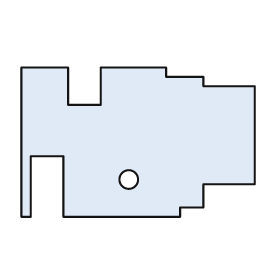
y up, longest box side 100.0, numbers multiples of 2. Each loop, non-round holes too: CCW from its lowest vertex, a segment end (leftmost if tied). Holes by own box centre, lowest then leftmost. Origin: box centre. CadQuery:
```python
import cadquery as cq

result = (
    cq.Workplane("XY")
    .moveTo(-50.0, -32.0)
    .lineTo(-46.0, -32.0)
    .lineTo(-46.0, -6.0)
    .lineTo(-32.0, -6.0)
    .lineTo(-32.0, -32.0)
    .lineTo(18.0, -32.0)
    .lineTo(18.0, -28.0)
    .lineTo(28.0, -28.0)
    .lineTo(28.0, -18.0)
    .lineTo(50.0, -18.0)
    .lineTo(50.0, 24.0)
    .lineTo(28.0, 24.0)
    .lineTo(28.0, 28.0)
    .lineTo(12.0, 28.0)
    .lineTo(12.0, 32.0)
    .lineTo(-16.0, 32.0)
    .lineTo(-16.0, 16.0)
    .lineTo(-30.0, 16.0)
    .lineTo(-30.0, 32.0)
    .lineTo(-50.0, 32.0)
    .close()
    .moveTo(-4.0, -16.0)
    .circle(4.0)
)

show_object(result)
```